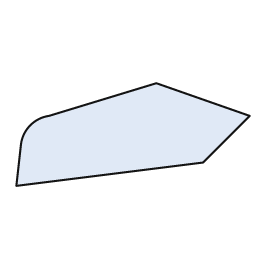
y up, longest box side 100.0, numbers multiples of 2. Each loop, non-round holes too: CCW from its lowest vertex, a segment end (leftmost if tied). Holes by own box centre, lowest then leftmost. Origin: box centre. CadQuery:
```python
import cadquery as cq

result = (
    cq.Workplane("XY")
    .moveTo(-50.0, -22.0)
    .lineTo(30.0, -12.0)
    .lineTo(50.0, 8.0)
    .lineTo(10.0, 22.0)
    .lineTo(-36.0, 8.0)
    .threePointArc((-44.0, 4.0), (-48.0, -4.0))
    .close()
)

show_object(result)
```